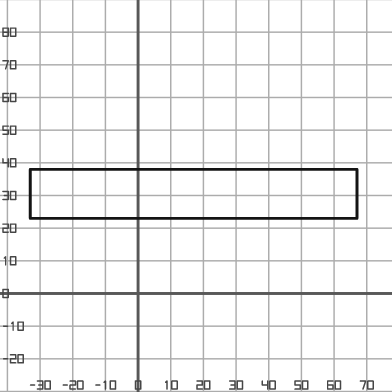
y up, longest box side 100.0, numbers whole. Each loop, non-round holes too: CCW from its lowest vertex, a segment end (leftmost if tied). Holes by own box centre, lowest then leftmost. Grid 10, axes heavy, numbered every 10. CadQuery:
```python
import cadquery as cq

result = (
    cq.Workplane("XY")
    .moveTo(-33.0, 23.0)
    .lineTo(67.0, 23.0)
    .lineTo(67.0, 38.0)
    .lineTo(-33.0, 38.0)
    .close()
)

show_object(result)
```